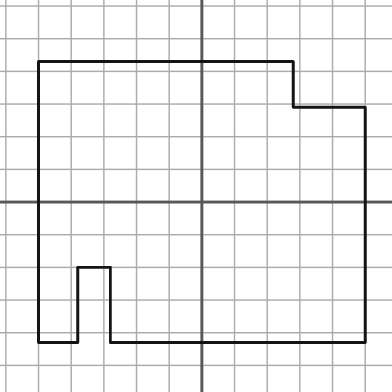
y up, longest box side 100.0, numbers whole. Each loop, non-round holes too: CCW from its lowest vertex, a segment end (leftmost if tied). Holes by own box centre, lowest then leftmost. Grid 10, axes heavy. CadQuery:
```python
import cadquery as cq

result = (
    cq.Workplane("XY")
    .moveTo(-50.0, -43.0)
    .lineTo(-38.0, -43.0)
    .lineTo(-38.0, -20.0)
    .lineTo(-28.0, -20.0)
    .lineTo(-28.0, -43.0)
    .lineTo(50.0, -43.0)
    .lineTo(50.0, 29.0)
    .lineTo(28.0, 29.0)
    .lineTo(28.0, 43.0)
    .lineTo(-50.0, 43.0)
    .close()
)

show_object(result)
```